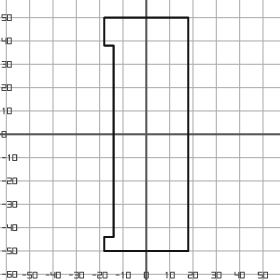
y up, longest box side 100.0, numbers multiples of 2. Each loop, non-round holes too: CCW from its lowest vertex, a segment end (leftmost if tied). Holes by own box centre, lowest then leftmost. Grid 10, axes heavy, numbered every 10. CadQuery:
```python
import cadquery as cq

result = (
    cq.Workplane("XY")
    .moveTo(-18.0, -50.0)
    .lineTo(18.0, -50.0)
    .lineTo(18.0, 50.0)
    .lineTo(-18.0, 50.0)
    .lineTo(-18.0, 38.0)
    .lineTo(-14.0, 38.0)
    .lineTo(-14.0, -44.0)
    .lineTo(-18.0, -44.0)
    .close()
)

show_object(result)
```